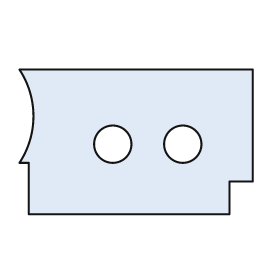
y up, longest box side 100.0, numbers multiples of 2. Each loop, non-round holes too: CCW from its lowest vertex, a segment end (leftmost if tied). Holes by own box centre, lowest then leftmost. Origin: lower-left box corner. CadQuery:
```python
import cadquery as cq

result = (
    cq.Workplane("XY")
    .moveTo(4.0, 0.0)
    .lineTo(90.0, 0.0)
    .lineTo(90.0, 14.0)
    .lineTo(100.0, 14.0)
    .lineTo(100.0, 62.0)
    .lineTo(0.0, 62.0)
    .threePointArc((6.0, 42.0), (0.0, 22.0))
    .lineTo(4.0, 22.0)
    .close()
    .moveTo(40.0, 30.0)
    .circle(8.0)
    .moveTo(70.0, 30.0)
    .circle(8.0)
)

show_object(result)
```